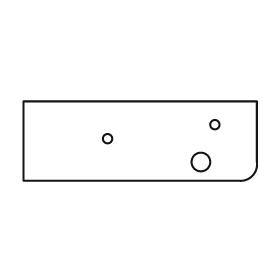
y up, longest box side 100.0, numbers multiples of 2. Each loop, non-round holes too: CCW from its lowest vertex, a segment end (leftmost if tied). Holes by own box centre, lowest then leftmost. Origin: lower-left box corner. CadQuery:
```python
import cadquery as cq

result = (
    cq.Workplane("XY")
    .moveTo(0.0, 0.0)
    .lineTo(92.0, 0.0)
    .threePointArc((98.0, 2.0), (100.0, 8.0))
    .lineTo(100.0, 34.0)
    .lineTo(0.0, 34.0)
    .close()
    .moveTo(76.0, 8.0)
    .circle(4.0)
    .moveTo(36.0, 18.0)
    .circle(2.0)
    .moveTo(82.0, 24.0)
    .circle(2.0)
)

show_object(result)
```